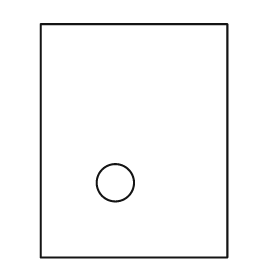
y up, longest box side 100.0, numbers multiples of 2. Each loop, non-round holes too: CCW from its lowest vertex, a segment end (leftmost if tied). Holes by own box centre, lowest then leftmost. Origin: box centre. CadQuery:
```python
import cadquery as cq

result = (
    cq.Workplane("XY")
    .moveTo(-40.0, -50.0)
    .lineTo(40.0, -50.0)
    .lineTo(40.0, 50.0)
    .lineTo(-40.0, 50.0)
    .close()
    .moveTo(-8.0, -18.0)
    .circle(8.0)
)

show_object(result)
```